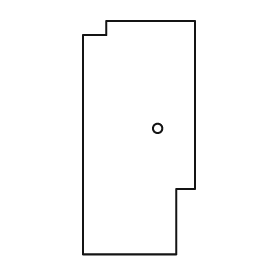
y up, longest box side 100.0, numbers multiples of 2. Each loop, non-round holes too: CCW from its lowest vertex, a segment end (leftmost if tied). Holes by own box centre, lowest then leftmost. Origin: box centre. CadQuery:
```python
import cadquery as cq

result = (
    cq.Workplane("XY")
    .moveTo(-24.0, -50.0)
    .lineTo(16.0, -50.0)
    .lineTo(16.0, -22.0)
    .lineTo(24.0, -22.0)
    .lineTo(24.0, 50.0)
    .lineTo(-14.0, 50.0)
    .lineTo(-14.0, 44.0)
    .lineTo(-24.0, 44.0)
    .close()
    .moveTo(8.0, 4.0)
    .circle(2.0)
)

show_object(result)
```